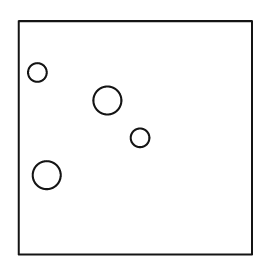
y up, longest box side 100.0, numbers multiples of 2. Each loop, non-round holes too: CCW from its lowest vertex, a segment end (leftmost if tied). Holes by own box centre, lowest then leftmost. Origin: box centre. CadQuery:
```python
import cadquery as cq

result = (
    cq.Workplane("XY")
    .moveTo(-50.0, -50.0)
    .lineTo(50.0, -50.0)
    .lineTo(50.0, 50.0)
    .lineTo(-50.0, 50.0)
    .close()
    .moveTo(-38.0, -16.0)
    .circle(6.0)
    .moveTo(2.0, 0.0)
    .circle(4.0)
    .moveTo(-12.0, 16.0)
    .circle(6.0)
    .moveTo(-42.0, 28.0)
    .circle(4.0)
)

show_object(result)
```